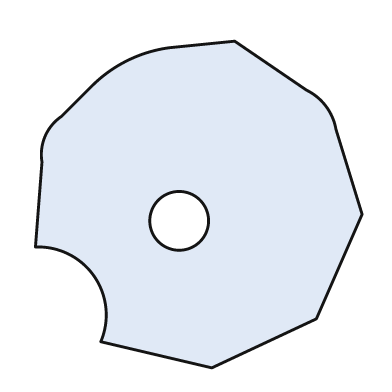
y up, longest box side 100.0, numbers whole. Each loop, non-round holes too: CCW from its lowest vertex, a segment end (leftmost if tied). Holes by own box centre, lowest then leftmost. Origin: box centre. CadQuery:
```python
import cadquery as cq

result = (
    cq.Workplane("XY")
    .moveTo(4.0, -50.0)
    .lineTo(36.0, -35.0)
    .lineTo(50.0, -3.0)
    .lineTo(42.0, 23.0)
    .threePointArc((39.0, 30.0), (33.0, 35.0))
    .lineTo(11.0, 50.0)
    .lineTo(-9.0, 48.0)
    .threePointArc((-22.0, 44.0), (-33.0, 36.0))
    .lineTo(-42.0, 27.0)
    .threePointArc((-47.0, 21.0), (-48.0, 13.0))
    .lineTo(-50.0, -13.0)
    .threePointArc((-32.0, -22.0), (-30.0, -42.0))
    .close()
    .moveTo(-6.0, -5.0)
    .circle(9.0)
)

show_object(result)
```